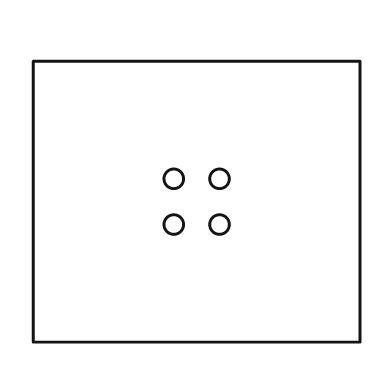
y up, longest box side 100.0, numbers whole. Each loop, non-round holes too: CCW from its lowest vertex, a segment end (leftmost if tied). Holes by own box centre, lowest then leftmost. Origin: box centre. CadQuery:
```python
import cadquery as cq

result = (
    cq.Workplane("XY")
    .moveTo(-50.0, -43.0)
    .lineTo(50.0, -43.0)
    .lineTo(50.0, 43.0)
    .lineTo(-50.0, 43.0)
    .close()
    .moveTo(-7.0, -7.0)
    .circle(3.0)
    .moveTo(7.0, -7.0)
    .circle(3.0)
    .moveTo(-7.0, 7.0)
    .circle(3.0)
    .moveTo(7.0, 7.0)
    .circle(3.0)
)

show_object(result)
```